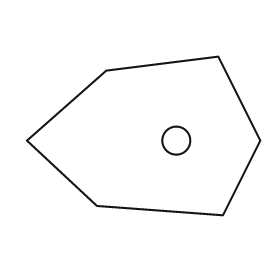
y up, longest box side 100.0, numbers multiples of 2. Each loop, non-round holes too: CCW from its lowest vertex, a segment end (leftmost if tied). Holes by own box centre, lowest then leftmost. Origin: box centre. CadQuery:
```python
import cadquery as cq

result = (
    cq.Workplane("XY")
    .moveTo(34.0, -34.0)
    .lineTo(50.0, -2.0)
    .lineTo(32.0, 34.0)
    .lineTo(-16.0, 28.0)
    .lineTo(-50.0, -2.0)
    .lineTo(-20.0, -30.0)
    .close()
    .moveTo(14.0, -2.0)
    .circle(6.0)
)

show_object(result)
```